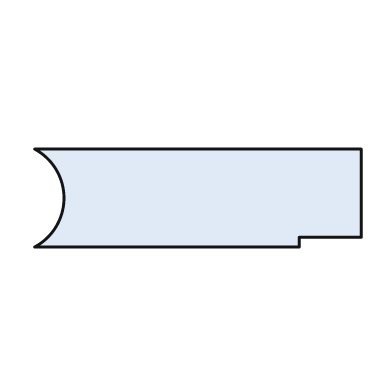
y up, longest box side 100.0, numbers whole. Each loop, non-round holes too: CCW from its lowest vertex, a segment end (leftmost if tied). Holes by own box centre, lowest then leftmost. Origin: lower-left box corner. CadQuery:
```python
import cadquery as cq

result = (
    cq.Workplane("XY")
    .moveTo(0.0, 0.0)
    .lineTo(81.0, 0.0)
    .lineTo(81.0, 3.0)
    .lineTo(100.0, 3.0)
    .lineTo(100.0, 30.0)
    .lineTo(0.0, 30.0)
    .threePointArc((9.0, 15.0), (0.0, 0.0))
    .close()
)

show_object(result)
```